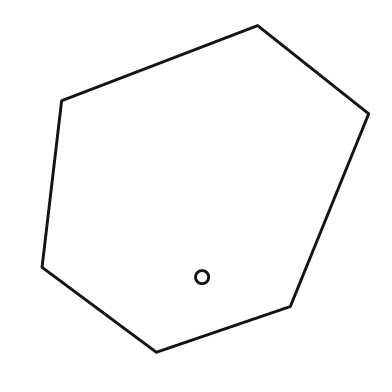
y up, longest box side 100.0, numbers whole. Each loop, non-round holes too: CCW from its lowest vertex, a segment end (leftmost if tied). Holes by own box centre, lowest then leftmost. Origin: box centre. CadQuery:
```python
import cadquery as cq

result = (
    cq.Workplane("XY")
    .moveTo(-15.0, -50.0)
    .lineTo(26.0, -36.0)
    .lineTo(50.0, 23.0)
    .lineTo(16.0, 50.0)
    .lineTo(-44.0, 27.0)
    .lineTo(-50.0, -24.0)
    .close()
    .moveTo(-1.0, -27.0)
    .circle(2.0)
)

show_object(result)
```